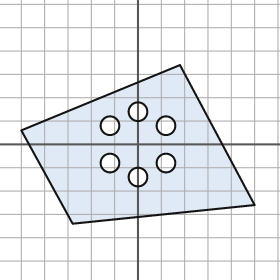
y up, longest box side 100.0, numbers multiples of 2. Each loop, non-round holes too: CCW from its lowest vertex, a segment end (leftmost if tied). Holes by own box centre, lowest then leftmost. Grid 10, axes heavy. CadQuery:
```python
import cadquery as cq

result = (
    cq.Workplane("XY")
    .moveTo(-28.0, -34.0)
    .lineTo(50.0, -26.0)
    .lineTo(18.0, 34.0)
    .lineTo(-50.0, 6.0)
    .close()
    .moveTo(0.0, -14.0)
    .circle(4.0)
    .moveTo(-12.0, -8.0)
    .circle(4.0)
    .moveTo(12.0, -8.0)
    .circle(4.0)
    .moveTo(-12.0, 8.0)
    .circle(4.0)
    .moveTo(12.0, 8.0)
    .circle(4.0)
    .moveTo(0.0, 14.0)
    .circle(4.0)
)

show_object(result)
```